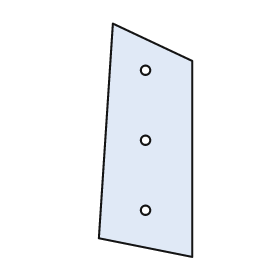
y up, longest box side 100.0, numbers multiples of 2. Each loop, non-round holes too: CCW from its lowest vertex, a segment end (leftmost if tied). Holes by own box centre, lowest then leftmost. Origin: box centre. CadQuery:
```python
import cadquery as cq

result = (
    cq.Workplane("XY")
    .moveTo(20.0, -50.0)
    .lineTo(20.0, 34.0)
    .lineTo(-14.0, 50.0)
    .lineTo(-20.0, -42.0)
    .close()
    .moveTo(0.0, -30.0)
    .circle(2.0)
    .moveTo(0.0, 0.0)
    .circle(2.0)
    .moveTo(0.0, 30.0)
    .circle(2.0)
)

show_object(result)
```